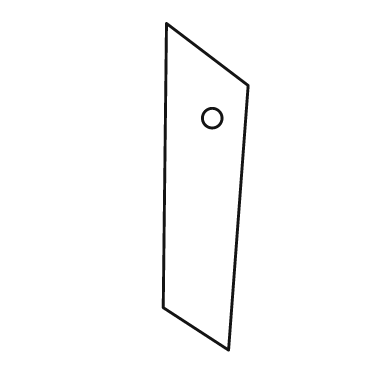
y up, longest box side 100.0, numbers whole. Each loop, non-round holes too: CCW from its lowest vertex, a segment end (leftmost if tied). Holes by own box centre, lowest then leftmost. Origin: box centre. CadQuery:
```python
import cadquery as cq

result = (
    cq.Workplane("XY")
    .moveTo(7.0, -50.0)
    .lineTo(13.0, 31.0)
    .lineTo(-12.0, 50.0)
    .lineTo(-13.0, -37.0)
    .close()
    .moveTo(2.0, 21.0)
    .circle(3.0)
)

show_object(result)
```